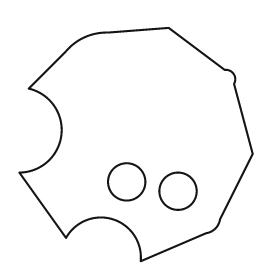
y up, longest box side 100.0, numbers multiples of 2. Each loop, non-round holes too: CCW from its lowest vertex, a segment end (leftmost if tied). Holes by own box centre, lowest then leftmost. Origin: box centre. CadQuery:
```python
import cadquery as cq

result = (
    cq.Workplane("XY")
    .moveTo(2.0, -50.0)
    .lineTo(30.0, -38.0)
    .threePointArc((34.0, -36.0), (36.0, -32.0))
    .lineTo(50.0, -4.0)
    .lineTo(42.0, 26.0)
    .threePointArc((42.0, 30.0), (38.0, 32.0))
    .lineTo(14.0, 50.0)
    .lineTo(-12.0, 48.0)
    .threePointArc((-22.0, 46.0), (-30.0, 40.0))
    .lineTo(-46.0, 24.0)
    .threePointArc((-32.0, 4.0), (-50.0, -12.0))
    .lineTo(-30.0, -40.0)
    .threePointArc((-10.0, -32.0), (2.0, -50.0))
    .close()
    .moveTo(18.0, -20.0)
    .circle(8.0)
    .moveTo(-4.0, -16.0)
    .circle(8.0)
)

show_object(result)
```